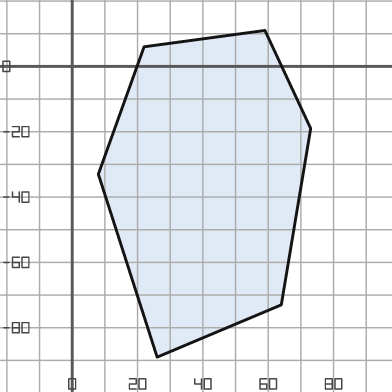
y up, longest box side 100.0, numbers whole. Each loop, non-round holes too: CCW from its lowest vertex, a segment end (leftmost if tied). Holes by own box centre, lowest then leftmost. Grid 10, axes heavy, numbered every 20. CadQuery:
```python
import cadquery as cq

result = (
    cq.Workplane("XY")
    .moveTo(26.0, -89.0)
    .lineTo(64.0, -73.0)
    .lineTo(73.0, -19.0)
    .lineTo(59.0, 11.0)
    .lineTo(22.0, 6.0)
    .lineTo(8.0, -33.0)
    .close()
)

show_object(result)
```